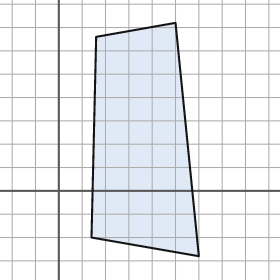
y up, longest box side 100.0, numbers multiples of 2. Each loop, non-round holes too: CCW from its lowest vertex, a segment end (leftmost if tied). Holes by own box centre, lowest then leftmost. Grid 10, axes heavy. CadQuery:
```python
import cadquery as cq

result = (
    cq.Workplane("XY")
    .moveTo(60.0, -28.0)
    .lineTo(50.0, 72.0)
    .lineTo(16.0, 66.0)
    .lineTo(14.0, -20.0)
    .close()
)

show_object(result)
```